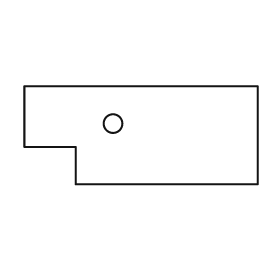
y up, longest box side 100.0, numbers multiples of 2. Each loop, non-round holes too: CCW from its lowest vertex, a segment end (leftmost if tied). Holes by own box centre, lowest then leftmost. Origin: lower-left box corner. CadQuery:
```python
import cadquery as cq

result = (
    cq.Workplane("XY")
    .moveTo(22.0, 0.0)
    .lineTo(100.0, 0.0)
    .lineTo(100.0, 42.0)
    .lineTo(0.0, 42.0)
    .lineTo(0.0, 16.0)
    .lineTo(22.0, 16.0)
    .close()
    .moveTo(38.0, 26.0)
    .circle(4.0)
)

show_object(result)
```